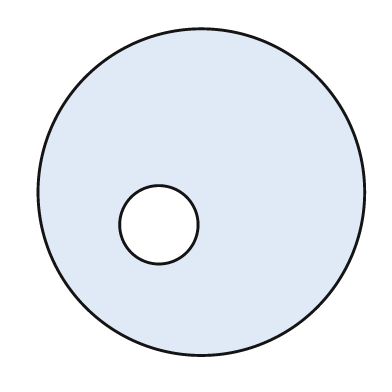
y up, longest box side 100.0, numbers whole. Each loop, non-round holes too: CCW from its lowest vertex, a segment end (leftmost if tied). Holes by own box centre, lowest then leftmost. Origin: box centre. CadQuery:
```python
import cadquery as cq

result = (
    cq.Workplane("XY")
    .moveTo(0.0, 0.0)
    .circle(50.0)
    .moveTo(-13.0, -10.0)
    .circle(12.0)
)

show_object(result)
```